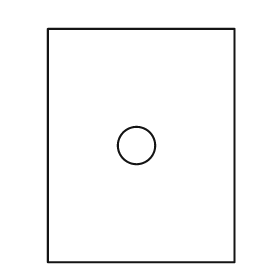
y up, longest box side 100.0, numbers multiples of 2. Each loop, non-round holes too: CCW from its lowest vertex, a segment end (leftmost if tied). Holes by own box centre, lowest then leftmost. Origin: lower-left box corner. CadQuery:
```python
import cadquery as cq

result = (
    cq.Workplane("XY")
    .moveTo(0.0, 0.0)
    .lineTo(80.0, 0.0)
    .lineTo(80.0, 100.0)
    .lineTo(0.0, 100.0)
    .close()
    .moveTo(38.0, 50.0)
    .circle(8.0)
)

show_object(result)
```